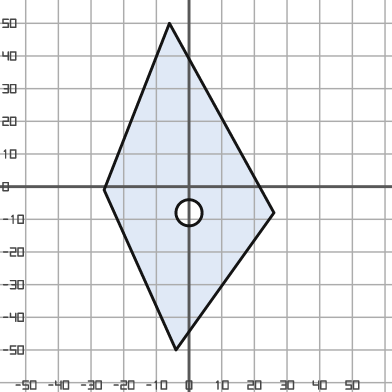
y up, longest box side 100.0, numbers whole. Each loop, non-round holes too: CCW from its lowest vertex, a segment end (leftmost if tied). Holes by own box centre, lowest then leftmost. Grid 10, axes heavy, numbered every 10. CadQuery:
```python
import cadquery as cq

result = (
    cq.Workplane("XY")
    .moveTo(-4.0, -50.0)
    .lineTo(26.0, -8.0)
    .lineTo(-6.0, 50.0)
    .lineTo(-26.0, -1.0)
    .close()
    .moveTo(0.0, -8.0)
    .circle(4.0)
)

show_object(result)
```